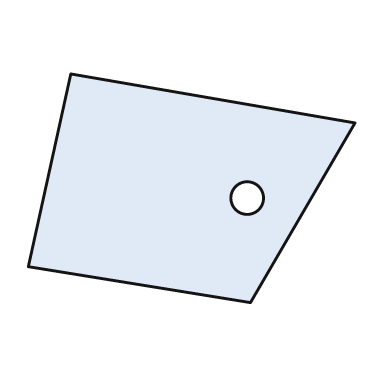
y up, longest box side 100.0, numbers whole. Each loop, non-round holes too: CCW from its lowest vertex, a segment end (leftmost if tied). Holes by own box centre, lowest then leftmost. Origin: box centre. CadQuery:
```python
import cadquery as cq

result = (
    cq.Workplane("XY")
    .moveTo(18.0, -35.0)
    .lineTo(50.0, 20.0)
    .lineTo(-37.0, 35.0)
    .lineTo(-50.0, -24.0)
    .close()
    .moveTo(17.0, -3.0)
    .circle(5.0)
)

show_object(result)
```